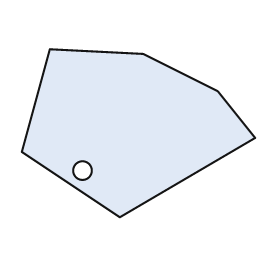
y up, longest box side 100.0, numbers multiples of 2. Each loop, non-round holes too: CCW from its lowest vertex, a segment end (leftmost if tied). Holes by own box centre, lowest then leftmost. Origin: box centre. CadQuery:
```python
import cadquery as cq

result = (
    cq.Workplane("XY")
    .moveTo(-8.0, -36.0)
    .lineTo(50.0, -2.0)
    .lineTo(34.0, 18.0)
    .lineTo(2.0, 34.0)
    .lineTo(-38.0, 36.0)
    .lineTo(-50.0, -8.0)
    .close()
    .moveTo(-24.0, -16.0)
    .circle(4.0)
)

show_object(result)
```